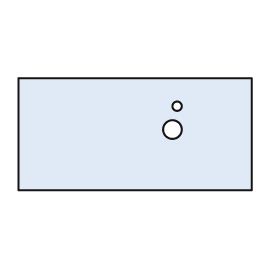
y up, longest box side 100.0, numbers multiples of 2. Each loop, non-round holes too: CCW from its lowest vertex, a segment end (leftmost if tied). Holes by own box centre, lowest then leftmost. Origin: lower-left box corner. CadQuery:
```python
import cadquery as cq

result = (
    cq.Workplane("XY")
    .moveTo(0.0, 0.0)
    .lineTo(100.0, 0.0)
    .lineTo(100.0, 48.0)
    .lineTo(0.0, 48.0)
    .close()
    .moveTo(66.0, 26.0)
    .circle(4.0)
    .moveTo(68.0, 36.0)
    .circle(2.0)
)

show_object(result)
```